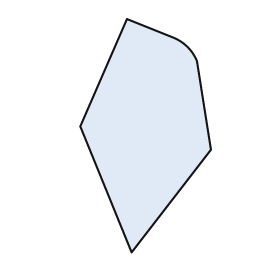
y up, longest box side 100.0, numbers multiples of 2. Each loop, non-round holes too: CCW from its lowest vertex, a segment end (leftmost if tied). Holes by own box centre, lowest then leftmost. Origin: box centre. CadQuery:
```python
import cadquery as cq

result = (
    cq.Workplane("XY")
    .moveTo(-6.0, -50.0)
    .lineTo(28.0, -6.0)
    .lineTo(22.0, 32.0)
    .threePointArc((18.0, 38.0), (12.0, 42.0))
    .lineTo(-8.0, 50.0)
    .lineTo(-28.0, 4.0)
    .close()
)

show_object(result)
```